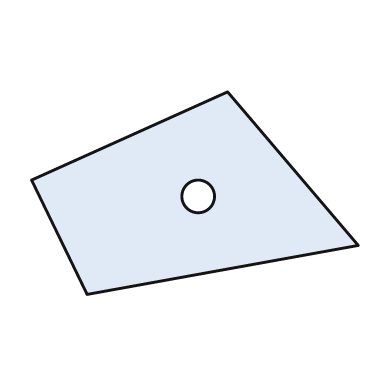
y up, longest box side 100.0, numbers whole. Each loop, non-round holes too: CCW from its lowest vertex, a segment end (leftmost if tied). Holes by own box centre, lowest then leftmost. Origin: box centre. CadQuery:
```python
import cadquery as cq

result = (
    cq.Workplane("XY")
    .moveTo(-33.0, -31.0)
    .lineTo(50.0, -16.0)
    .lineTo(10.0, 31.0)
    .lineTo(-50.0, 4.0)
    .close()
    .moveTo(1.0, -1.0)
    .circle(5.0)
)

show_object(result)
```